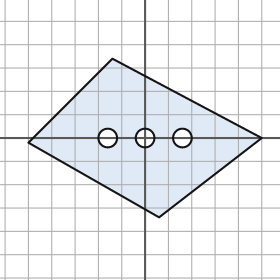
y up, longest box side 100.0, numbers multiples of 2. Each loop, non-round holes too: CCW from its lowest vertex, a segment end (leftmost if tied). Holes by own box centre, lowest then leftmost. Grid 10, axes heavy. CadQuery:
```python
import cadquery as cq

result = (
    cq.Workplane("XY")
    .moveTo(6.0, -34.0)
    .lineTo(50.0, 0.0)
    .lineTo(-14.0, 34.0)
    .lineTo(-50.0, -2.0)
    .close()
    .moveTo(-16.0, 0.0)
    .circle(4.0)
    .moveTo(0.0, 0.0)
    .circle(4.0)
    .moveTo(16.0, 0.0)
    .circle(4.0)
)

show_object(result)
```